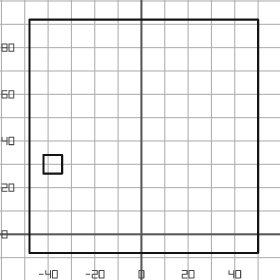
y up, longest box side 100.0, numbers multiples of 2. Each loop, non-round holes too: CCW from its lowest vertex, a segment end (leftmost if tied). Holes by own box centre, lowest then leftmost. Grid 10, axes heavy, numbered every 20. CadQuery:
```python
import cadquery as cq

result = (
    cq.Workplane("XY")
    .moveTo(-48.0, -8.0)
    .lineTo(50.0, -8.0)
    .lineTo(50.0, 92.0)
    .lineTo(-48.0, 92.0)
    .close()
    .moveTo(-42.0, 26.0)
    .lineTo(-34.0, 26.0)
    .lineTo(-34.0, 34.0)
    .lineTo(-42.0, 34.0)
    .close()
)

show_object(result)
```